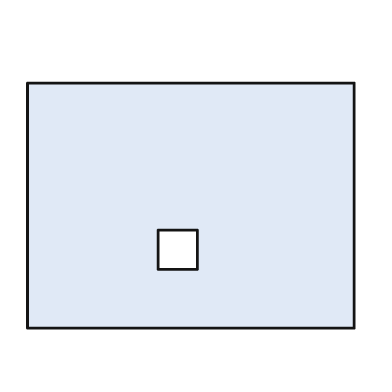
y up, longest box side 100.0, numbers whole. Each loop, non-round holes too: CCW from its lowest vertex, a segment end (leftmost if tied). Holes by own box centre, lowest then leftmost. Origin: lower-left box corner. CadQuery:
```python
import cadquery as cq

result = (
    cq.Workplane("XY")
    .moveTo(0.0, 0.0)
    .lineTo(100.0, 0.0)
    .lineTo(100.0, 75.0)
    .lineTo(0.0, 75.0)
    .close()
    .moveTo(40.0, 18.0)
    .lineTo(52.0, 18.0)
    .lineTo(52.0, 30.0)
    .lineTo(40.0, 30.0)
    .close()
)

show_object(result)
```